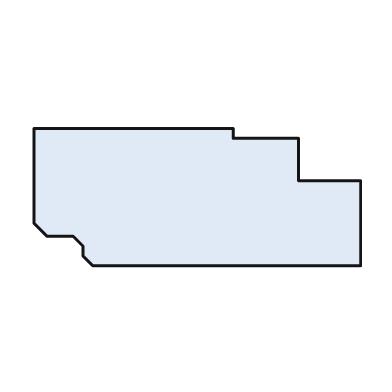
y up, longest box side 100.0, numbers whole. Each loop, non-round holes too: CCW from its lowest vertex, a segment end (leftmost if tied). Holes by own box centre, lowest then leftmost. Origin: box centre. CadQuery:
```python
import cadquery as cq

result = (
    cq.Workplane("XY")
    .moveTo(-32.0, -21.0)
    .lineTo(50.0, -21.0)
    .lineTo(50.0, 5.0)
    .lineTo(31.0, 5.0)
    .lineTo(31.0, 18.0)
    .lineTo(11.0, 18.0)
    .lineTo(11.0, 21.0)
    .lineTo(-50.0, 21.0)
    .lineTo(-50.0, -8.0)
    .lineTo(-46.0, -12.0)
    .lineTo(-38.0, -12.0)
    .lineTo(-35.0, -15.0)
    .lineTo(-35.0, -18.0)
    .close()
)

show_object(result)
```